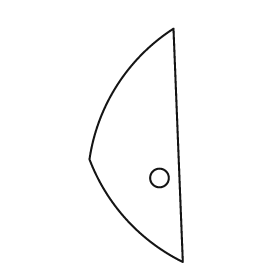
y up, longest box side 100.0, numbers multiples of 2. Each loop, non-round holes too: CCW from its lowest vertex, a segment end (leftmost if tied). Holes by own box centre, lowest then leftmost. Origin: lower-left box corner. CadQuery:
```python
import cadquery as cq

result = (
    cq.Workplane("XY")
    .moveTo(40.0, 0.0)
    .lineTo(36.0, 100.0)
    .threePointArc((12.0, 76.0), (0.0, 44.0))
    .threePointArc((16.0, 18.0), (40.0, 0.0))
    .close()
    .moveTo(30.0, 36.0)
    .circle(4.0)
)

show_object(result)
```